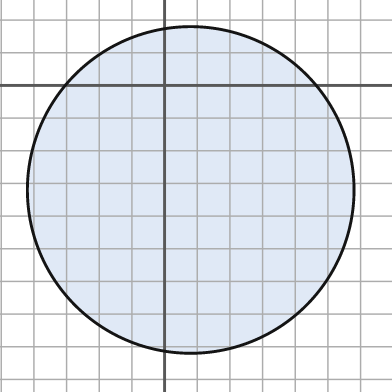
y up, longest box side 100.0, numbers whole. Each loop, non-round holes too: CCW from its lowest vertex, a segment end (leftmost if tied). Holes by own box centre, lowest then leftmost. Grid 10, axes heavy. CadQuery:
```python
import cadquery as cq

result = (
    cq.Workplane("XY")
    .moveTo(8.0, -32.0)
    .circle(50.0)
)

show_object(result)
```